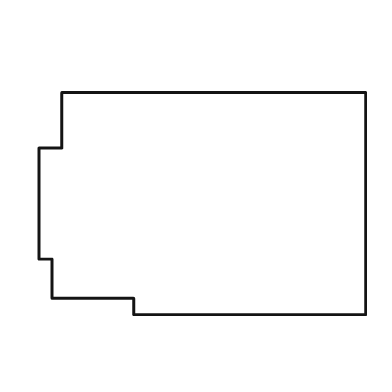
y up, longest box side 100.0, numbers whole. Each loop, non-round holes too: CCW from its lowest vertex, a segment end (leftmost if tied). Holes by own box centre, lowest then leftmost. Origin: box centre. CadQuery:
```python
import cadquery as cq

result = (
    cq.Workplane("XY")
    .moveTo(-21.0, -34.0)
    .lineTo(50.0, -34.0)
    .lineTo(50.0, 34.0)
    .lineTo(-43.0, 34.0)
    .lineTo(-43.0, 17.0)
    .lineTo(-50.0, 17.0)
    .lineTo(-50.0, -17.0)
    .lineTo(-46.0, -17.0)
    .lineTo(-46.0, -29.0)
    .lineTo(-21.0, -29.0)
    .close()
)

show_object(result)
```